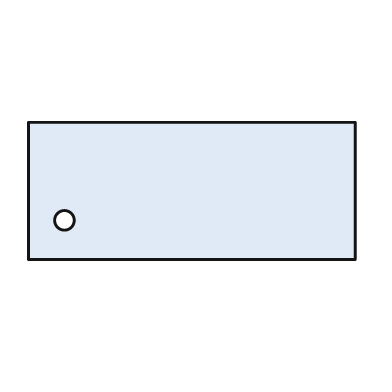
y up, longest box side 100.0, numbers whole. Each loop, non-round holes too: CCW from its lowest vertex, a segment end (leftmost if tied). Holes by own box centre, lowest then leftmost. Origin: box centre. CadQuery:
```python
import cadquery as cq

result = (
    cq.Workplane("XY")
    .moveTo(-50.0, -21.0)
    .lineTo(50.0, -21.0)
    .lineTo(50.0, 21.0)
    .lineTo(-50.0, 21.0)
    .close()
    .moveTo(-39.0, -9.0)
    .circle(3.0)
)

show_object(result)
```